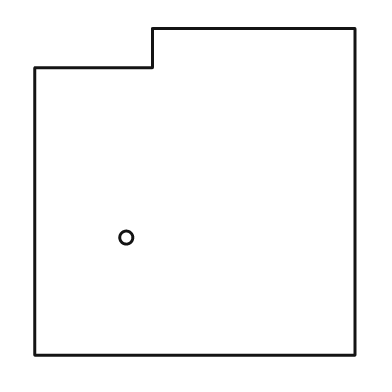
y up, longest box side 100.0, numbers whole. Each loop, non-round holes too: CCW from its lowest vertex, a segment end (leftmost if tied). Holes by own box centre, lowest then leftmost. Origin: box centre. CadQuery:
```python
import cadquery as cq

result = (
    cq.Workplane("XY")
    .moveTo(-49.0, -50.0)
    .lineTo(49.0, -50.0)
    .lineTo(49.0, 50.0)
    .lineTo(-13.0, 50.0)
    .lineTo(-13.0, 38.0)
    .lineTo(-49.0, 38.0)
    .close()
    .moveTo(-21.0, -14.0)
    .circle(2.0)
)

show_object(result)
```